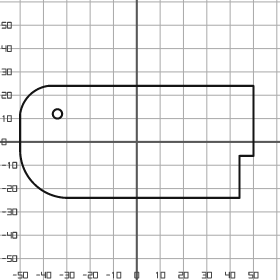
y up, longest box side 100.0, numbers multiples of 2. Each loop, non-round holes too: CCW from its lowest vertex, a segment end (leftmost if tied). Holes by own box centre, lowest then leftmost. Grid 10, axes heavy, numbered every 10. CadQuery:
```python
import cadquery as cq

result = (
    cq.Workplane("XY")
    .moveTo(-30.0, -24.0)
    .lineTo(44.0, -24.0)
    .lineTo(44.0, -6.0)
    .lineTo(50.0, -6.0)
    .lineTo(50.0, 24.0)
    .lineTo(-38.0, 24.0)
    .threePointArc((-46.0, 20.0), (-50.0, 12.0))
    .lineTo(-50.0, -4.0)
    .threePointArc((-44.0, -18.0), (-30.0, -24.0))
    .close()
    .moveTo(-34.0, 12.0)
    .circle(2.0)
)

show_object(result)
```